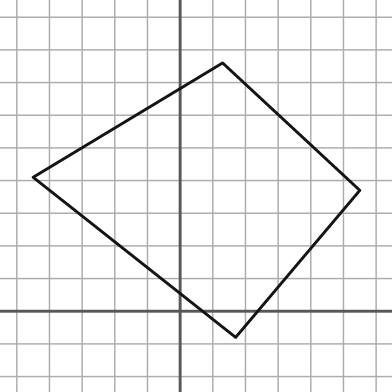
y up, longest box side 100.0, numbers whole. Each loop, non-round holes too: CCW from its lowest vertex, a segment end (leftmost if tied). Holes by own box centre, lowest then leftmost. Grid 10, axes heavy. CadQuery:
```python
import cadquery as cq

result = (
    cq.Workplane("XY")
    .moveTo(17.0, -8.0)
    .lineTo(55.0, 37.0)
    .lineTo(13.0, 76.0)
    .lineTo(-45.0, 41.0)
    .close()
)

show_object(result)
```